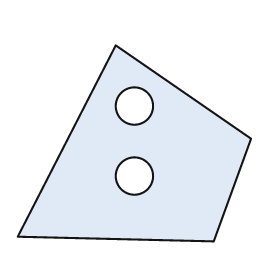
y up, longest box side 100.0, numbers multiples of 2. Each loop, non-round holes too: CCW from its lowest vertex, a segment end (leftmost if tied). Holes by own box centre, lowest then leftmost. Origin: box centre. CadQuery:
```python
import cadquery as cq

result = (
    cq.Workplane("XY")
    .moveTo(34.0, -42.0)
    .lineTo(50.0, 2.0)
    .lineTo(-8.0, 42.0)
    .lineTo(-50.0, -40.0)
    .close()
    .moveTo(0.0, -14.0)
    .circle(8.0)
    .moveTo(0.0, 16.0)
    .circle(8.0)
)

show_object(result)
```